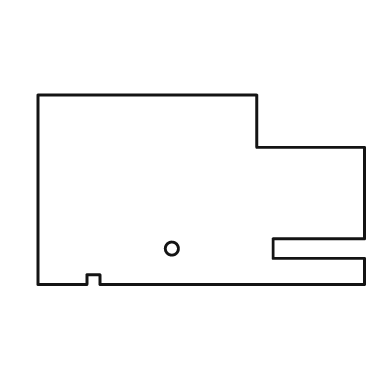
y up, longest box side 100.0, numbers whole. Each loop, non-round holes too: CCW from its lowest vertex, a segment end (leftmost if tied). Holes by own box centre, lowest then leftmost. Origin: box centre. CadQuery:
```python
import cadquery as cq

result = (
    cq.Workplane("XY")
    .moveTo(-50.0, -29.0)
    .lineTo(-35.0, -29.0)
    .lineTo(-35.0, -26.0)
    .lineTo(-31.0, -26.0)
    .lineTo(-31.0, -29.0)
    .lineTo(50.0, -29.0)
    .lineTo(50.0, -21.0)
    .lineTo(22.0, -21.0)
    .lineTo(22.0, -15.0)
    .lineTo(50.0, -15.0)
    .lineTo(50.0, 13.0)
    .lineTo(17.0, 13.0)
    .lineTo(17.0, 29.0)
    .lineTo(-50.0, 29.0)
    .close()
    .moveTo(-9.0, -18.0)
    .circle(2.0)
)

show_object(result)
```